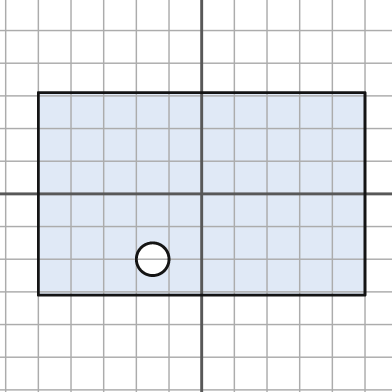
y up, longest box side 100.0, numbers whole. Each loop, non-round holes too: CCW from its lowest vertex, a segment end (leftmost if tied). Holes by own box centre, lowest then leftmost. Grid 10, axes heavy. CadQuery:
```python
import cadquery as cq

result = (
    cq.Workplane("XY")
    .moveTo(-50.0, -31.0)
    .lineTo(50.0, -31.0)
    .lineTo(50.0, 31.0)
    .lineTo(-50.0, 31.0)
    .close()
    .moveTo(-15.0, -20.0)
    .circle(5.0)
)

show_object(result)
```